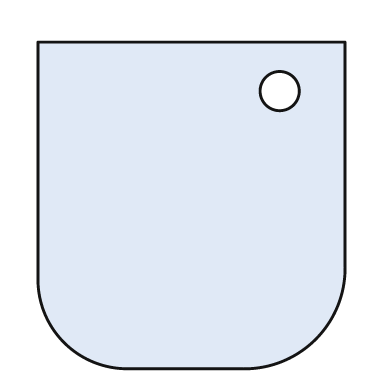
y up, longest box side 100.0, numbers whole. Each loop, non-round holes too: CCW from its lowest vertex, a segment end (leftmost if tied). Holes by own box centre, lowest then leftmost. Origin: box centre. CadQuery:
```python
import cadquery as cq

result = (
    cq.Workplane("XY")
    .moveTo(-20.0, -50.0)
    .lineTo(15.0, -50.0)
    .threePointArc((38.0, -41.0), (47.0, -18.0))
    .lineTo(47.0, 50.0)
    .lineTo(-47.0, 50.0)
    .lineTo(-47.0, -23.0)
    .threePointArc((-39.0, -42.0), (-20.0, -50.0))
    .close()
    .moveTo(27.0, 35.0)
    .circle(6.0)
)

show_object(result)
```